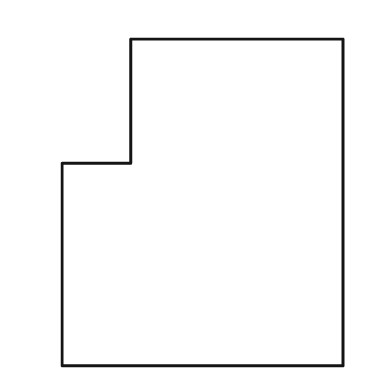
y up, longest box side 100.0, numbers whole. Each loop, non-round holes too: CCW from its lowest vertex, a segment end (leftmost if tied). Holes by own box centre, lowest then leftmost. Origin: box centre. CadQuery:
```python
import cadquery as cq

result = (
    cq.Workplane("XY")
    .moveTo(-43.0, -50.0)
    .lineTo(43.0, -50.0)
    .lineTo(43.0, 50.0)
    .lineTo(-22.0, 50.0)
    .lineTo(-22.0, 12.0)
    .lineTo(-43.0, 12.0)
    .close()
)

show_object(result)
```